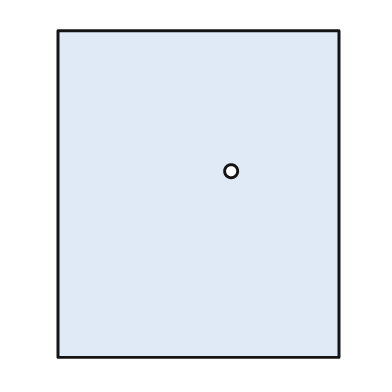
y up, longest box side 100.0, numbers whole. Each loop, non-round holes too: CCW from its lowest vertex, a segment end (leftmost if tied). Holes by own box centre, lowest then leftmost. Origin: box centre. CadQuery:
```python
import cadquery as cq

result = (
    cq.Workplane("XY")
    .moveTo(-43.0, -50.0)
    .lineTo(43.0, -50.0)
    .lineTo(43.0, 50.0)
    .lineTo(-43.0, 50.0)
    .close()
    .moveTo(10.0, 7.0)
    .circle(2.0)
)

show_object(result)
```